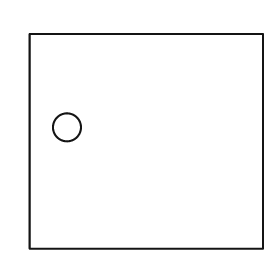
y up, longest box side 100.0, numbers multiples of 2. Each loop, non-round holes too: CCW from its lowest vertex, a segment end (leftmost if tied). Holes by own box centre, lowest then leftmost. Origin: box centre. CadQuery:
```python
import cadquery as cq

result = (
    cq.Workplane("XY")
    .moveTo(-50.0, -46.0)
    .lineTo(50.0, -46.0)
    .lineTo(50.0, 46.0)
    .lineTo(-50.0, 46.0)
    .close()
    .moveTo(-34.0, 6.0)
    .circle(6.0)
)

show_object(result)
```